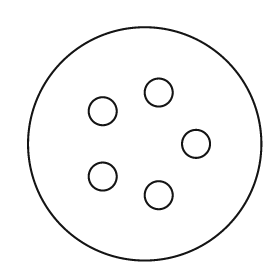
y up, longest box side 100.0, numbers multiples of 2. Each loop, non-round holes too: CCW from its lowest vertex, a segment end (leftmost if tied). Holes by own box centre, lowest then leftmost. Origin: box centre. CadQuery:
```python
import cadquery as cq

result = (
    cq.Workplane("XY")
    .moveTo(0.0, 0.0)
    .circle(50.0)
    .moveTo(6.0, -22.0)
    .circle(6.0)
    .moveTo(-18.0, -14.0)
    .circle(6.0)
    .moveTo(22.0, 0.0)
    .circle(6.0)
    .moveTo(-18.0, 14.0)
    .circle(6.0)
    .moveTo(6.0, 22.0)
    .circle(6.0)
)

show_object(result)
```